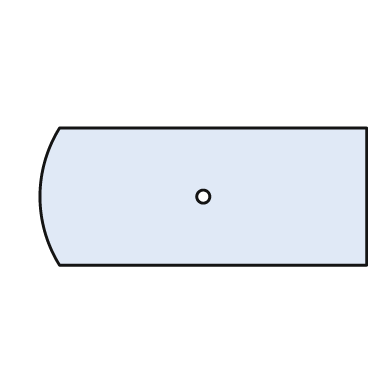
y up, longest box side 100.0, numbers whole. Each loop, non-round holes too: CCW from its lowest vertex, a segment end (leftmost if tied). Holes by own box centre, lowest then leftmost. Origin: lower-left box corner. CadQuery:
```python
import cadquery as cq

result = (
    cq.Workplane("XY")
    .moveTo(6.0, 0.0)
    .lineTo(100.0, 0.0)
    .lineTo(100.0, 42.0)
    .lineTo(6.0, 42.0)
    .threePointArc((0.0, 21.0), (6.0, 0.0))
    .close()
    .moveTo(50.0, 21.0)
    .circle(2.0)
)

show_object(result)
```